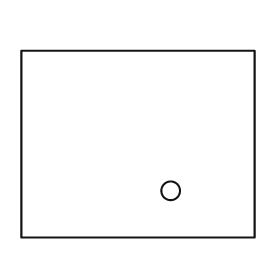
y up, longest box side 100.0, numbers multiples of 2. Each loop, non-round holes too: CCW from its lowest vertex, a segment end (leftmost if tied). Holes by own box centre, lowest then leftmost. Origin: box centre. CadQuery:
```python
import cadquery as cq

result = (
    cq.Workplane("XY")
    .moveTo(-50.0, -40.0)
    .lineTo(50.0, -40.0)
    .lineTo(50.0, 40.0)
    .lineTo(-50.0, 40.0)
    .close()
    .moveTo(14.0, -20.0)
    .circle(4.0)
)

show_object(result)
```